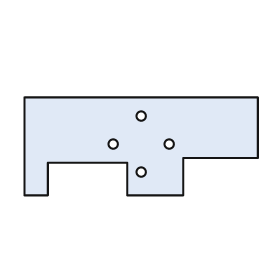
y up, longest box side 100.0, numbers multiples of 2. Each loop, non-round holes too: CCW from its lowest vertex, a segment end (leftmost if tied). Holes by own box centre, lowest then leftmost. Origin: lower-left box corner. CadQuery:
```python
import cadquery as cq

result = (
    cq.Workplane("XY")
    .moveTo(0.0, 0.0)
    .lineTo(10.0, 0.0)
    .lineTo(10.0, 14.0)
    .lineTo(44.0, 14.0)
    .lineTo(44.0, 0.0)
    .lineTo(68.0, 0.0)
    .lineTo(68.0, 16.0)
    .lineTo(100.0, 16.0)
    .lineTo(100.0, 42.0)
    .lineTo(0.0, 42.0)
    .close()
    .moveTo(50.0, 10.0)
    .circle(2.0)
    .moveTo(38.0, 22.0)
    .circle(2.0)
    .moveTo(62.0, 22.0)
    .circle(2.0)
    .moveTo(50.0, 34.0)
    .circle(2.0)
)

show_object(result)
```